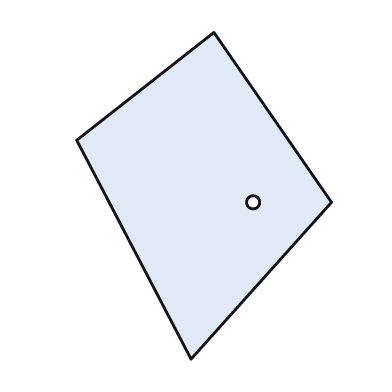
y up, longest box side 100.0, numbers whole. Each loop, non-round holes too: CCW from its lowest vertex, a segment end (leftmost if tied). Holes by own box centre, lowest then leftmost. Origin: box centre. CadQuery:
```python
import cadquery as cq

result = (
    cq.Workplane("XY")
    .moveTo(-4.0, -50.0)
    .lineTo(39.0, -2.0)
    .lineTo(3.0, 50.0)
    .lineTo(-39.0, 17.0)
    .close()
    .moveTo(15.0, -2.0)
    .circle(2.0)
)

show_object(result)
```